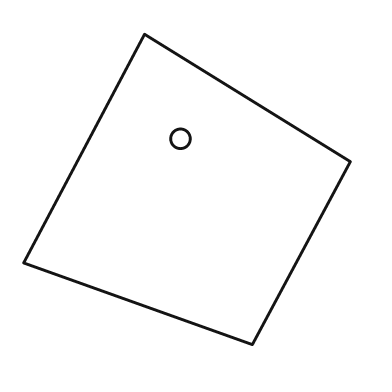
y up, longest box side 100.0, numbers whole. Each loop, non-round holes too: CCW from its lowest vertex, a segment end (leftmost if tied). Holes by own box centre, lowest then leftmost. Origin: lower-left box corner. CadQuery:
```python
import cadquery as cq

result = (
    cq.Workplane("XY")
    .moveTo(70.0, 0.0)
    .lineTo(100.0, 56.0)
    .lineTo(37.0, 95.0)
    .lineTo(0.0, 25.0)
    .close()
    .moveTo(48.0, 63.0)
    .circle(3.0)
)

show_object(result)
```